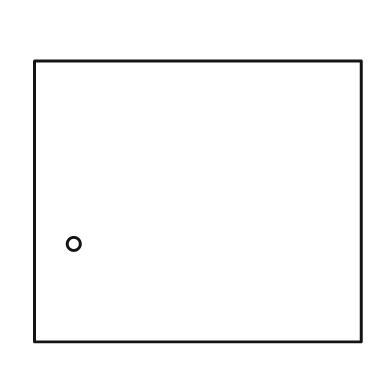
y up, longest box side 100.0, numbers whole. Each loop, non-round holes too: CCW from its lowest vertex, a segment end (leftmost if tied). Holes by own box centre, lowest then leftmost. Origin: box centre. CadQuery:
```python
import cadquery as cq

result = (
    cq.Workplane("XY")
    .moveTo(-50.0, -43.0)
    .lineTo(50.0, -43.0)
    .lineTo(50.0, 43.0)
    .lineTo(-50.0, 43.0)
    .close()
    .moveTo(-38.0, -13.0)
    .circle(2.0)
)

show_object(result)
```